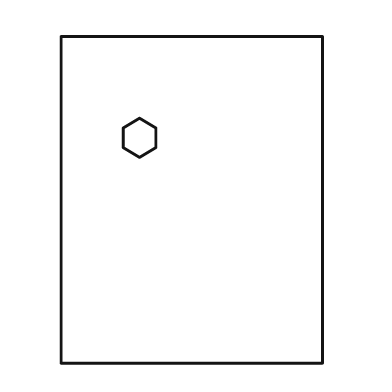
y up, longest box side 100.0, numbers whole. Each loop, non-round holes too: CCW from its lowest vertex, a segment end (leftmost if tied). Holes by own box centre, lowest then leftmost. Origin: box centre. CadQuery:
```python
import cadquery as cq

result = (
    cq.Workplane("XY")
    .moveTo(-40.0, -50.0)
    .lineTo(40.0, -50.0)
    .lineTo(40.0, 50.0)
    .lineTo(-40.0, 50.0)
    .close()
    .moveTo(-16.0, 13.0)
    .lineTo(-11.0, 16.0)
    .lineTo(-11.0, 22.0)
    .lineTo(-16.0, 25.0)
    .lineTo(-21.0, 22.0)
    .lineTo(-21.0, 16.0)
    .close()
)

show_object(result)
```